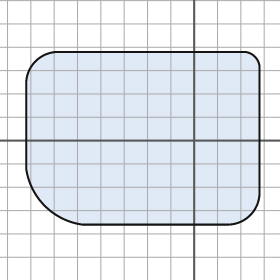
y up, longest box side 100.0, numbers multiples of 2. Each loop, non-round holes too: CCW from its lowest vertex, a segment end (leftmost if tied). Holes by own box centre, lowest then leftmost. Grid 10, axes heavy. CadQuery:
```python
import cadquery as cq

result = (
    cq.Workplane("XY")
    .moveTo(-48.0, -36.0)
    .lineTo(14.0, -36.0)
    .threePointArc((24.0, -32.0), (28.0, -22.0))
    .lineTo(28.0, 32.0)
    .threePointArc((26.0, 36.0), (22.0, 38.0))
    .lineTo(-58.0, 38.0)
    .threePointArc((-68.0, 34.0), (-72.0, 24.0))
    .lineTo(-72.0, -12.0)
    .threePointArc((-64.0, -28.0), (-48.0, -36.0))
    .close()
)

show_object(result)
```